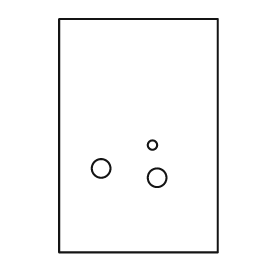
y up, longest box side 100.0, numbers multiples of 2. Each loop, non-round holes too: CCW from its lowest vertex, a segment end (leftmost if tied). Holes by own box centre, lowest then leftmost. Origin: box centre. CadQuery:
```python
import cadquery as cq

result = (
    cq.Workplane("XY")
    .moveTo(-34.0, -50.0)
    .lineTo(34.0, -50.0)
    .lineTo(34.0, 50.0)
    .lineTo(-34.0, 50.0)
    .close()
    .moveTo(8.0, -18.0)
    .circle(4.0)
    .moveTo(-16.0, -14.0)
    .circle(4.0)
    .moveTo(6.0, -4.0)
    .circle(2.0)
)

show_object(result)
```